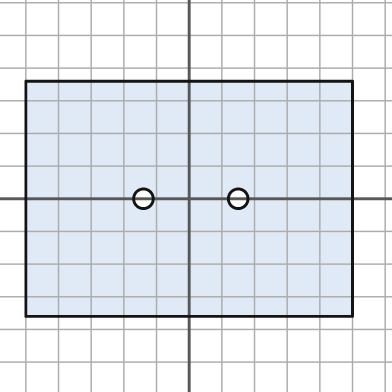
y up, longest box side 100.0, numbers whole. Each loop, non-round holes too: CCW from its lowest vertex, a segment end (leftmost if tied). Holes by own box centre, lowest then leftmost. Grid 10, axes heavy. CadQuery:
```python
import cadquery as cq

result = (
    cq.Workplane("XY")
    .moveTo(-50.0, -36.0)
    .lineTo(50.0, -36.0)
    .lineTo(50.0, 36.0)
    .lineTo(-50.0, 36.0)
    .close()
    .moveTo(-14.0, 0.0)
    .circle(3.0)
    .moveTo(15.0, 0.0)
    .circle(3.0)
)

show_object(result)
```